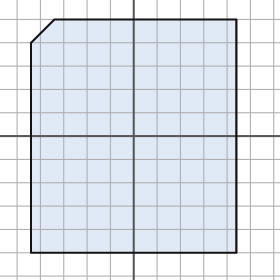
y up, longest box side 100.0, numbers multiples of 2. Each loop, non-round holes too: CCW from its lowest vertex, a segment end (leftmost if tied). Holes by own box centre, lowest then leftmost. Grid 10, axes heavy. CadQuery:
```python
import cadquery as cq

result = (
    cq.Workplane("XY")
    .moveTo(-44.0, -50.0)
    .lineTo(44.0, -50.0)
    .lineTo(44.0, 50.0)
    .lineTo(-34.0, 50.0)
    .lineTo(-44.0, 40.0)
    .close()
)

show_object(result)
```